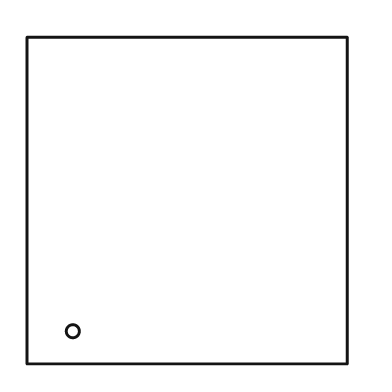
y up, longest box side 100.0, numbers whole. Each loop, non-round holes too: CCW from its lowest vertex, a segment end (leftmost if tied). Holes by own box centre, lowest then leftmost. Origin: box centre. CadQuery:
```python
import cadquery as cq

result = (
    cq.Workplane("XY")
    .moveTo(-49.0, -50.0)
    .lineTo(49.0, -50.0)
    .lineTo(49.0, 50.0)
    .lineTo(-49.0, 50.0)
    .close()
    .moveTo(-35.0, -40.0)
    .circle(2.0)
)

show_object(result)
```